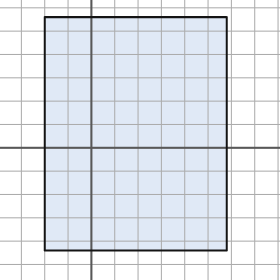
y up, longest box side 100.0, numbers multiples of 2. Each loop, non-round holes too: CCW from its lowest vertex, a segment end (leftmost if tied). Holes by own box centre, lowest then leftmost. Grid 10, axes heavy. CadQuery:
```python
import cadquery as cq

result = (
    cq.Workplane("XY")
    .moveTo(-20.0, -44.0)
    .lineTo(58.0, -44.0)
    .lineTo(58.0, 56.0)
    .lineTo(-20.0, 56.0)
    .close()
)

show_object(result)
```